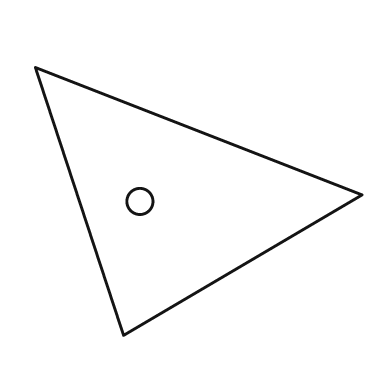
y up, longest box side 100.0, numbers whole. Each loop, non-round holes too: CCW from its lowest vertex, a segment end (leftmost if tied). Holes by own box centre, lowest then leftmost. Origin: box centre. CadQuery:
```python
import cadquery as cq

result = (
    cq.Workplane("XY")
    .moveTo(-23.0, -41.0)
    .lineTo(50.0, 2.0)
    .lineTo(-50.0, 41.0)
    .close()
    .moveTo(-18.0, 0.0)
    .circle(4.0)
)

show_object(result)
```